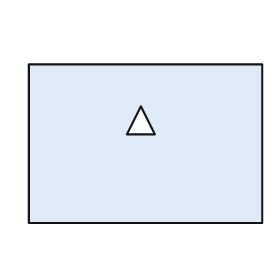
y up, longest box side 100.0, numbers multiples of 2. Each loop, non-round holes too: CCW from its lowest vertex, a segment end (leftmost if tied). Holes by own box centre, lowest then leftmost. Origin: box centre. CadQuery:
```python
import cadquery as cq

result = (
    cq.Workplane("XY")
    .moveTo(-50.0, -34.0)
    .lineTo(50.0, -34.0)
    .lineTo(50.0, 34.0)
    .lineTo(-50.0, 34.0)
    .close()
    .moveTo(-8.0, 4.0)
    .lineTo(4.0, 4.0)
    .lineTo(-2.0, 16.0)
    .close()
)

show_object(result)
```